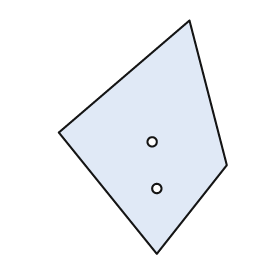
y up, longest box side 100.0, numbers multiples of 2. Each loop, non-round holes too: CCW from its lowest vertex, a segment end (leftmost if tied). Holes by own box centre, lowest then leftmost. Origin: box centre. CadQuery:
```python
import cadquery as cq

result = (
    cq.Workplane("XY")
    .moveTo(6.0, -50.0)
    .lineTo(36.0, -12.0)
    .lineTo(20.0, 50.0)
    .lineTo(-36.0, 2.0)
    .close()
    .moveTo(6.0, -22.0)
    .circle(2.0)
    .moveTo(4.0, -2.0)
    .circle(2.0)
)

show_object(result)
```